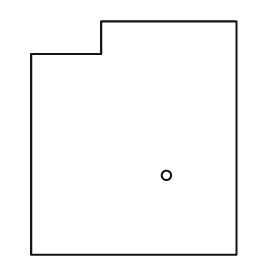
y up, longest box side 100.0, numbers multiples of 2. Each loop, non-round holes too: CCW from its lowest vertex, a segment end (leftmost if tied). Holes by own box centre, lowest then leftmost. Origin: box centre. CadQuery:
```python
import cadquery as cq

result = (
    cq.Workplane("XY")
    .moveTo(-44.0, -50.0)
    .lineTo(44.0, -50.0)
    .lineTo(44.0, 50.0)
    .lineTo(-14.0, 50.0)
    .lineTo(-14.0, 36.0)
    .lineTo(-44.0, 36.0)
    .close()
    .moveTo(14.0, -16.0)
    .circle(2.0)
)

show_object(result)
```